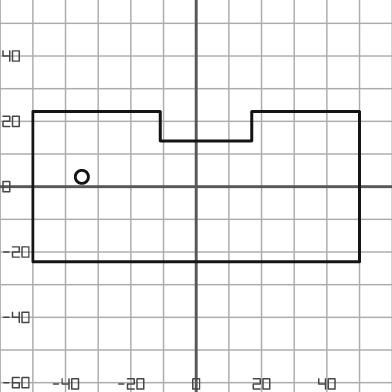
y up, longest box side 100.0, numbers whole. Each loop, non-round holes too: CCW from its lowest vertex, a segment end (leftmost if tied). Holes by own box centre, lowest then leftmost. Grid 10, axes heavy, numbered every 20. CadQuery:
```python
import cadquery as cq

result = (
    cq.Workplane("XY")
    .moveTo(-50.0, -23.0)
    .lineTo(50.0, -23.0)
    .lineTo(50.0, 23.0)
    .lineTo(17.0, 23.0)
    .lineTo(17.0, 14.0)
    .lineTo(-11.0, 14.0)
    .lineTo(-11.0, 23.0)
    .lineTo(-50.0, 23.0)
    .close()
    .moveTo(-35.0, 3.0)
    .circle(2.0)
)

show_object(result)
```